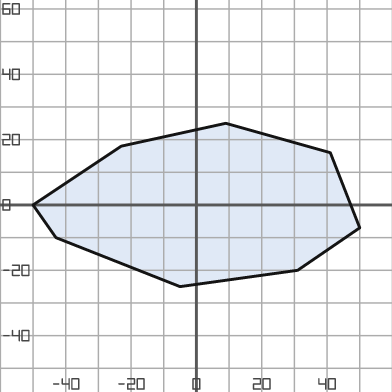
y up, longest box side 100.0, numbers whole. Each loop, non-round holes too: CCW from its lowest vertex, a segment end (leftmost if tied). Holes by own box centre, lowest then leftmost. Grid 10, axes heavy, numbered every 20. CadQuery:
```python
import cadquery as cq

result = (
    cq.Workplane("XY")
    .moveTo(-5.0, -25.0)
    .lineTo(31.0, -20.0)
    .lineTo(50.0, -7.0)
    .lineTo(41.0, 16.0)
    .lineTo(9.0, 25.0)
    .lineTo(-23.0, 18.0)
    .lineTo(-50.0, 0.0)
    .lineTo(-43.0, -10.0)
    .close()
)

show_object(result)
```